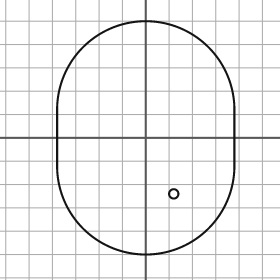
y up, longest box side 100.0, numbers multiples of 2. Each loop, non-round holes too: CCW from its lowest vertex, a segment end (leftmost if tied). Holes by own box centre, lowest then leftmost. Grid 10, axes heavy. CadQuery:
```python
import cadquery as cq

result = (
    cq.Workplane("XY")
    .moveTo(-38.0, -12.0)
    .threePointArc((0.0, -50.0), (38.0, -12.0))
    .lineTo(38.0, 12.0)
    .threePointArc((0.0, 50.0), (-38.0, 12.0))
    .close()
    .moveTo(12.0, -24.0)
    .circle(2.0)
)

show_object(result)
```